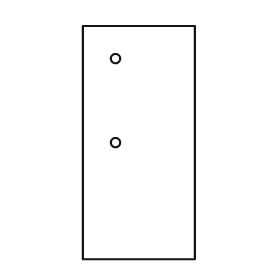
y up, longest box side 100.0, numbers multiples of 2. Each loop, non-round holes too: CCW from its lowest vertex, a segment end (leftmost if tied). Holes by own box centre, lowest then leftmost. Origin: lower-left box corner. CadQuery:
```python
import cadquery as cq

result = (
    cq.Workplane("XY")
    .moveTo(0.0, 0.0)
    .lineTo(48.0, 0.0)
    .lineTo(48.0, 100.0)
    .lineTo(0.0, 100.0)
    .close()
    .moveTo(14.0, 50.0)
    .circle(2.0)
    .moveTo(14.0, 86.0)
    .circle(2.0)
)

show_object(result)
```